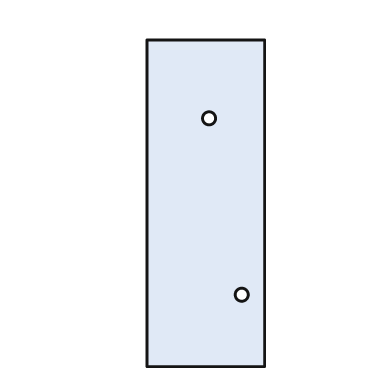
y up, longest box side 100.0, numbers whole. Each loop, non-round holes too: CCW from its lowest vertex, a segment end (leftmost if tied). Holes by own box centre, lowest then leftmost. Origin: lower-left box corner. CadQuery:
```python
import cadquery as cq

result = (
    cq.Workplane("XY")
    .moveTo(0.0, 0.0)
    .lineTo(36.0, 0.0)
    .lineTo(36.0, 100.0)
    .lineTo(0.0, 100.0)
    .close()
    .moveTo(29.0, 22.0)
    .circle(2.0)
    .moveTo(19.0, 76.0)
    .circle(2.0)
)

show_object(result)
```